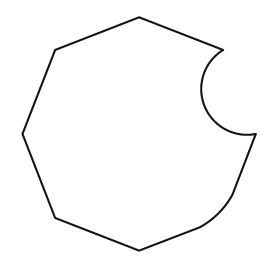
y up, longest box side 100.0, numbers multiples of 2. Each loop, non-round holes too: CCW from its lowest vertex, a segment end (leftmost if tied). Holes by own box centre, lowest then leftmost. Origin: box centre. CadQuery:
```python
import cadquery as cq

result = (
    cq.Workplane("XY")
    .moveTo(0.0, -50.0)
    .lineTo(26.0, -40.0)
    .threePointArc((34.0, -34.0), (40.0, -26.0))
    .lineTo(50.0, 0.0)
    .threePointArc((28.0, 12.0), (36.0, 36.0))
    .lineTo(0.0, 50.0)
    .lineTo(-36.0, 36.0)
    .lineTo(-50.0, 0.0)
    .lineTo(-36.0, -36.0)
    .close()
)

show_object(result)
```